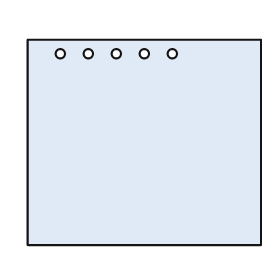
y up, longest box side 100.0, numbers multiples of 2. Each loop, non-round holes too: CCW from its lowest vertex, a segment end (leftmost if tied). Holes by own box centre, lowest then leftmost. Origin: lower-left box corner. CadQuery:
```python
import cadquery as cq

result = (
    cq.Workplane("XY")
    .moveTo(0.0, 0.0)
    .lineTo(100.0, 0.0)
    .lineTo(100.0, 88.0)
    .lineTo(0.0, 88.0)
    .close()
    .moveTo(14.0, 82.0)
    .circle(2.0)
    .moveTo(26.0, 82.0)
    .circle(2.0)
    .moveTo(38.0, 82.0)
    .circle(2.0)
    .moveTo(50.0, 82.0)
    .circle(2.0)
    .moveTo(62.0, 82.0)
    .circle(2.0)
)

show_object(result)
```